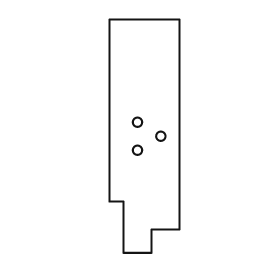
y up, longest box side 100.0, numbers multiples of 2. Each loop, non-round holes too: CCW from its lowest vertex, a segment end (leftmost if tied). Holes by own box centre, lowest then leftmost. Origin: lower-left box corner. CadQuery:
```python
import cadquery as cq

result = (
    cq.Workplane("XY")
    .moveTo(6.0, 0.0)
    .lineTo(18.0, 0.0)
    .lineTo(18.0, 10.0)
    .lineTo(30.0, 10.0)
    .lineTo(30.0, 100.0)
    .lineTo(0.0, 100.0)
    .lineTo(0.0, 22.0)
    .lineTo(6.0, 22.0)
    .close()
    .moveTo(12.0, 44.0)
    .circle(2.0)
    .moveTo(22.0, 50.0)
    .circle(2.0)
    .moveTo(12.0, 56.0)
    .circle(2.0)
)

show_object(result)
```